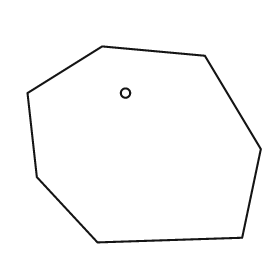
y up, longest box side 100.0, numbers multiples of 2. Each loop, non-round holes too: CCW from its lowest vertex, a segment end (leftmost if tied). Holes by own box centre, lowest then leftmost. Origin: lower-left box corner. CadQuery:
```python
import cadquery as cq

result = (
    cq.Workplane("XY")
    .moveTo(30.0, 0.0)
    .lineTo(92.0, 2.0)
    .lineTo(100.0, 40.0)
    .lineTo(76.0, 80.0)
    .lineTo(32.0, 84.0)
    .lineTo(0.0, 64.0)
    .lineTo(4.0, 28.0)
    .close()
    .moveTo(42.0, 64.0)
    .circle(2.0)
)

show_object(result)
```